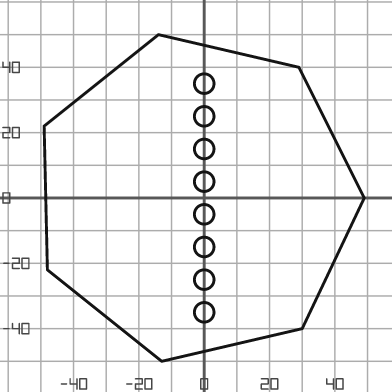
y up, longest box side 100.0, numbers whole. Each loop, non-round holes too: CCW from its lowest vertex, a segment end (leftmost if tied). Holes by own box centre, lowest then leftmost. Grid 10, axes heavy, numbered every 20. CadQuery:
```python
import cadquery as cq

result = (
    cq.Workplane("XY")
    .moveTo(-13.0, -50.0)
    .lineTo(30.0, -40.0)
    .lineTo(49.0, 0.0)
    .lineTo(29.0, 40.0)
    .lineTo(-14.0, 50.0)
    .lineTo(-49.0, 22.0)
    .lineTo(-48.0, -22.0)
    .close()
    .moveTo(0.0, -35.0)
    .circle(3.0)
    .moveTo(0.0, -25.0)
    .circle(3.0)
    .moveTo(0.0, -15.0)
    .circle(3.0)
    .moveTo(0.0, -5.0)
    .circle(3.0)
    .moveTo(0.0, 5.0)
    .circle(3.0)
    .moveTo(0.0, 15.0)
    .circle(3.0)
    .moveTo(0.0, 25.0)
    .circle(3.0)
    .moveTo(0.0, 35.0)
    .circle(3.0)
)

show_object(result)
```